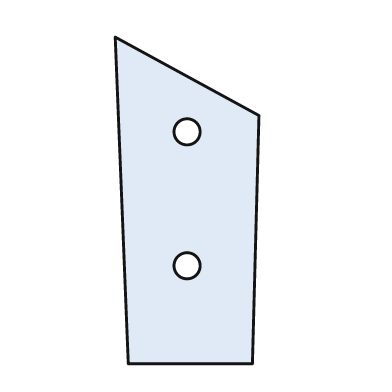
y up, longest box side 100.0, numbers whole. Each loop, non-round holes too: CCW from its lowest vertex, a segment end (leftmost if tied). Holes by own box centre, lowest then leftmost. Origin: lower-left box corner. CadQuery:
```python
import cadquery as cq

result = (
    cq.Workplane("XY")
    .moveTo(4.0, 0.0)
    .lineTo(42.0, 0.0)
    .lineTo(44.0, 76.0)
    .lineTo(0.0, 100.0)
    .close()
    .moveTo(22.0, 30.0)
    .circle(4.0)
    .moveTo(22.0, 71.0)
    .circle(4.0)
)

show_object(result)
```